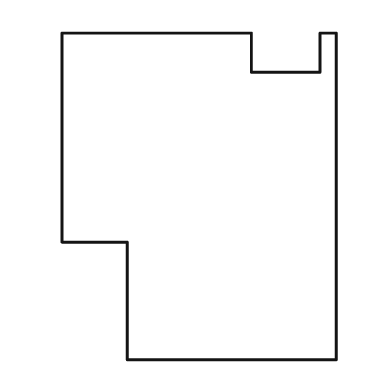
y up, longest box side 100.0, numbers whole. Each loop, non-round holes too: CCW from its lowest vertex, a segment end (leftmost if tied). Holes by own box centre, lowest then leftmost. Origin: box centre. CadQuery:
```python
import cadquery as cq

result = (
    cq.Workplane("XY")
    .moveTo(-22.0, -50.0)
    .lineTo(42.0, -50.0)
    .lineTo(42.0, 50.0)
    .lineTo(37.0, 50.0)
    .lineTo(37.0, 38.0)
    .lineTo(16.0, 38.0)
    .lineTo(16.0, 50.0)
    .lineTo(-42.0, 50.0)
    .lineTo(-42.0, -14.0)
    .lineTo(-22.0, -14.0)
    .close()
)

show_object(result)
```